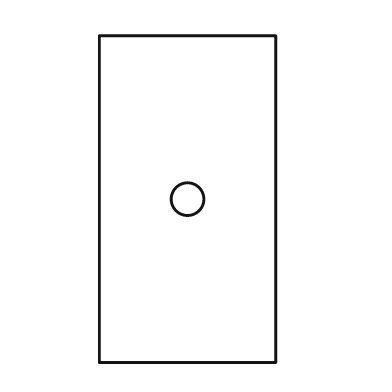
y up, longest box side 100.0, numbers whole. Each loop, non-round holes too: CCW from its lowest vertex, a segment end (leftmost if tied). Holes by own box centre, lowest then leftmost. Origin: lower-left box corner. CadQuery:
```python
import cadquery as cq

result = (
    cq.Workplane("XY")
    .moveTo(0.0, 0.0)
    .lineTo(54.0, 0.0)
    .lineTo(54.0, 100.0)
    .lineTo(0.0, 100.0)
    .close()
    .moveTo(27.0, 50.0)
    .circle(5.0)
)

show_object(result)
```